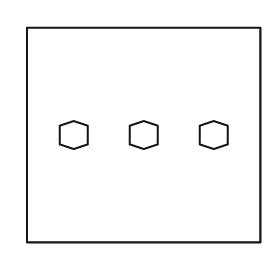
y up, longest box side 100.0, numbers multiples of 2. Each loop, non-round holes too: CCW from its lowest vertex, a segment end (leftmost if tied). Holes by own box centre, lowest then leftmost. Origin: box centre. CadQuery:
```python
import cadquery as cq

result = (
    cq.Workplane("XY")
    .moveTo(-50.0, -46.0)
    .lineTo(50.0, -46.0)
    .lineTo(50.0, 46.0)
    .lineTo(-50.0, 46.0)
    .close()
    .moveTo(-30.0, -6.0)
    .lineTo(-24.0, -4.0)
    .lineTo(-24.0, 4.0)
    .lineTo(-30.0, 6.0)
    .lineTo(-36.0, 4.0)
    .lineTo(-36.0, -4.0)
    .close()
    .moveTo(0.0, -6.0)
    .lineTo(6.0, -4.0)
    .lineTo(6.0, 4.0)
    .lineTo(0.0, 6.0)
    .lineTo(-6.0, 4.0)
    .lineTo(-6.0, -4.0)
    .close()
    .moveTo(30.0, -6.0)
    .lineTo(36.0, -4.0)
    .lineTo(36.0, 4.0)
    .lineTo(30.0, 6.0)
    .lineTo(24.0, 4.0)
    .lineTo(24.0, -4.0)
    .close()
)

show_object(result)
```